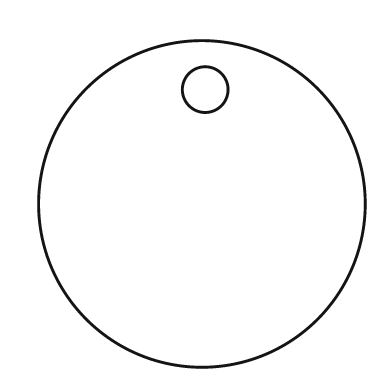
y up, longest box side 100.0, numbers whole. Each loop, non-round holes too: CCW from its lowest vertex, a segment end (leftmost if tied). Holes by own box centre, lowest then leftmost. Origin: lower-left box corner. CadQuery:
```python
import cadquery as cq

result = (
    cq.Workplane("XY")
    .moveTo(50.0, 50.0)
    .circle(50.0)
    .moveTo(51.0, 85.0)
    .circle(7.0)
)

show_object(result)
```